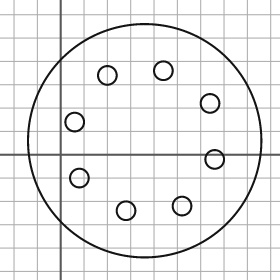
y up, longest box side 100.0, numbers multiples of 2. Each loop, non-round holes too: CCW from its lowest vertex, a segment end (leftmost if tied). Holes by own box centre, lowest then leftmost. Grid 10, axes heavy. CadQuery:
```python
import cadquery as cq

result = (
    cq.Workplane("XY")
    .moveTo(36.0, 6.0)
    .circle(50.0)
    .moveTo(28.0, -24.0)
    .circle(4.0)
    .moveTo(52.0, -22.0)
    .circle(4.0)
    .moveTo(8.0, -10.0)
    .circle(4.0)
    .moveTo(66.0, -2.0)
    .circle(4.0)
    .moveTo(6.0, 14.0)
    .circle(4.0)
    .moveTo(64.0, 22.0)
    .circle(4.0)
    .moveTo(20.0, 34.0)
    .circle(4.0)
    .moveTo(44.0, 36.0)
    .circle(4.0)
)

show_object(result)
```